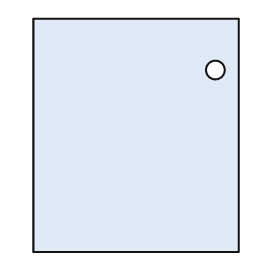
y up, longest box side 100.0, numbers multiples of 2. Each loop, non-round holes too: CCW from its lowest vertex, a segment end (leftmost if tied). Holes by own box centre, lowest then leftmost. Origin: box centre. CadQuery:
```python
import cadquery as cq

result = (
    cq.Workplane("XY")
    .moveTo(-44.0, -50.0)
    .lineTo(44.0, -50.0)
    .lineTo(44.0, 50.0)
    .lineTo(-44.0, 50.0)
    .close()
    .moveTo(34.0, 28.0)
    .circle(4.0)
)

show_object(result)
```